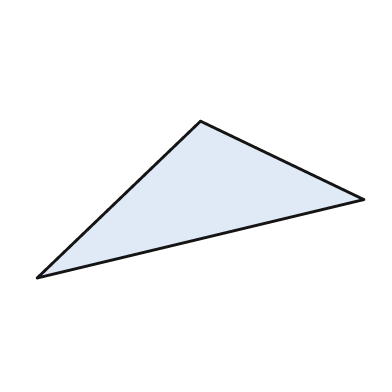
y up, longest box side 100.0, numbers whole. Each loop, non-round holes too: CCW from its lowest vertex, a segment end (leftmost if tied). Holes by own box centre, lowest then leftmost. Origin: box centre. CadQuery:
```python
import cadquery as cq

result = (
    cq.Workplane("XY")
    .moveTo(-50.0, -24.0)
    .lineTo(50.0, 0.0)
    .lineTo(0.0, 24.0)
    .close()
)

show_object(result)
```